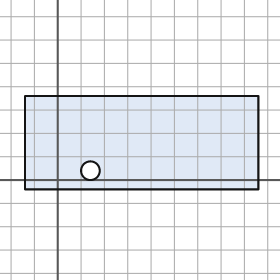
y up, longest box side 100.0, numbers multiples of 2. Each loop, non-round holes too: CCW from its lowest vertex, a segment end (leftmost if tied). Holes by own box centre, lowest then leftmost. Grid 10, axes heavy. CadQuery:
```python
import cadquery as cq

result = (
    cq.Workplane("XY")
    .moveTo(-14.0, -4.0)
    .lineTo(86.0, -4.0)
    .lineTo(86.0, 36.0)
    .lineTo(-14.0, 36.0)
    .close()
    .moveTo(14.0, 4.0)
    .circle(4.0)
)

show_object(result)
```